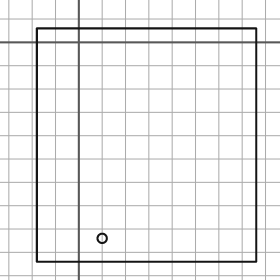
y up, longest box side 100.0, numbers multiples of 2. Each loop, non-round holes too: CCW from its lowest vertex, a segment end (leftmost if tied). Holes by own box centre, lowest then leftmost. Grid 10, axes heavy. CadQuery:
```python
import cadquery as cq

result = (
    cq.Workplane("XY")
    .moveTo(-18.0, -94.0)
    .lineTo(76.0, -94.0)
    .lineTo(76.0, 6.0)
    .lineTo(-18.0, 6.0)
    .close()
    .moveTo(10.0, -84.0)
    .circle(2.0)
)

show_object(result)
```